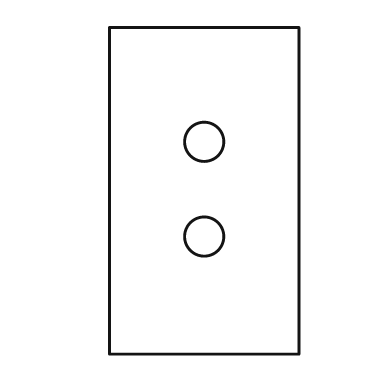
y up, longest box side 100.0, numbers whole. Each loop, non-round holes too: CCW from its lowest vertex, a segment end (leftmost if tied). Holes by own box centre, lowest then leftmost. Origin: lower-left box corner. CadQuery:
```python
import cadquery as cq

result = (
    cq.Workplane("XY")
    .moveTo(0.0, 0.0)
    .lineTo(58.0, 0.0)
    .lineTo(58.0, 100.0)
    .lineTo(0.0, 100.0)
    .close()
    .moveTo(29.0, 36.0)
    .circle(6.0)
    .moveTo(29.0, 65.0)
    .circle(6.0)
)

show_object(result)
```